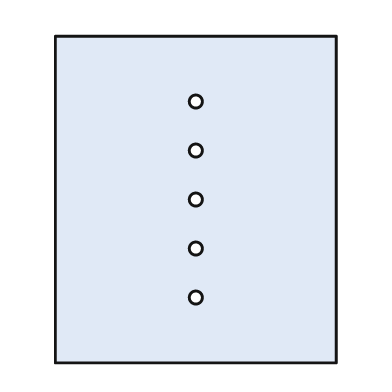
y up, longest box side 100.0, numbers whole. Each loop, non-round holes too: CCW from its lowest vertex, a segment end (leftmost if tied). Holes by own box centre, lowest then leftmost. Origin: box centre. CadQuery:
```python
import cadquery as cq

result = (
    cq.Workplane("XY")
    .moveTo(-43.0, -50.0)
    .lineTo(43.0, -50.0)
    .lineTo(43.0, 50.0)
    .lineTo(-43.0, 50.0)
    .close()
    .moveTo(0.0, -30.0)
    .circle(2.0)
    .moveTo(0.0, -15.0)
    .circle(2.0)
    .moveTo(0.0, 0.0)
    .circle(2.0)
    .moveTo(0.0, 15.0)
    .circle(2.0)
    .moveTo(0.0, 30.0)
    .circle(2.0)
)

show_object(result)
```